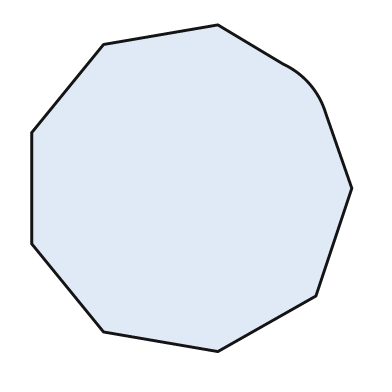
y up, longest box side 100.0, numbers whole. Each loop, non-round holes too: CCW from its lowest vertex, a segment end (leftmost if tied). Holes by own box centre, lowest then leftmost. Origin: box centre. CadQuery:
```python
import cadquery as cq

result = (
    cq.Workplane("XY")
    .moveTo(8.0, -50.0)
    .lineTo(38.0, -33.0)
    .lineTo(49.0, 0.0)
    .lineTo(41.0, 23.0)
    .threePointArc((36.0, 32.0), (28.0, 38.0))
    .lineTo(8.0, 50.0)
    .lineTo(-27.0, 44.0)
    .lineTo(-49.0, 17.0)
    .lineTo(-49.0, -17.0)
    .lineTo(-27.0, -44.0)
    .close()
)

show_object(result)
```